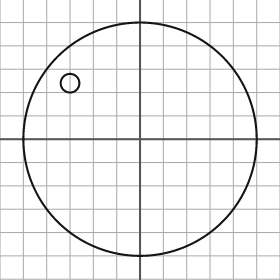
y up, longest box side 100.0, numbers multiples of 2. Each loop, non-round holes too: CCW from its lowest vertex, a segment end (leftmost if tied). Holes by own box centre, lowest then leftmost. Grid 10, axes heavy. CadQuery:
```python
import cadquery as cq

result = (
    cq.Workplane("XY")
    .moveTo(0.0, 0.0)
    .circle(50.0)
    .moveTo(-30.0, 24.0)
    .circle(4.0)
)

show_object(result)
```